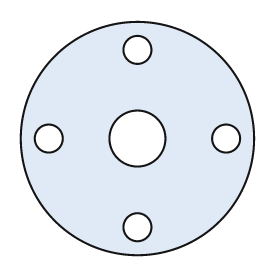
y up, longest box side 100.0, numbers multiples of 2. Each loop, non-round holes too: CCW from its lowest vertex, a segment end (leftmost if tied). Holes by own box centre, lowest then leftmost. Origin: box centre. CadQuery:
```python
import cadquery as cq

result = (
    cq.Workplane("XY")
    .moveTo(0.0, 0.0)
    .circle(50.0)
    .moveTo(0.0, -38.0)
    .circle(6.0)
    .moveTo(-38.0, 0.0)
    .circle(6.0)
    .moveTo(0.0, 0.0)
    .circle(12.0)
    .moveTo(38.0, 0.0)
    .circle(6.0)
    .moveTo(0.0, 38.0)
    .circle(6.0)
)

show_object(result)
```